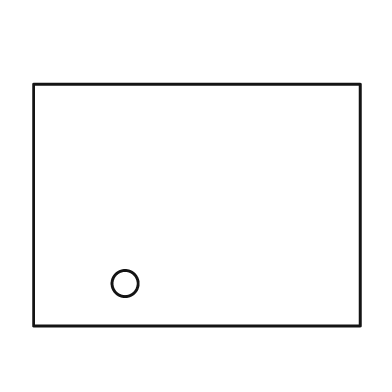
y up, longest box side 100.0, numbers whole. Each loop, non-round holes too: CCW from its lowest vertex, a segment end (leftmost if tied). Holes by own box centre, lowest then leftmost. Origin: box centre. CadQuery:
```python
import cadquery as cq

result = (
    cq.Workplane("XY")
    .moveTo(-50.0, -37.0)
    .lineTo(50.0, -37.0)
    .lineTo(50.0, 37.0)
    .lineTo(-50.0, 37.0)
    .close()
    .moveTo(-22.0, -24.0)
    .circle(4.0)
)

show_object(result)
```